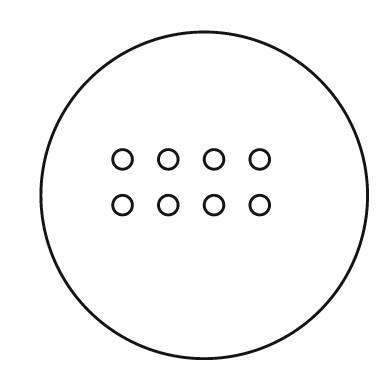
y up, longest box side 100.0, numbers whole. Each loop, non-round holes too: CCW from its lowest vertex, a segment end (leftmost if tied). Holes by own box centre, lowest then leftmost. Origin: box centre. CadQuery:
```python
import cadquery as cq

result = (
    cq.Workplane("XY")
    .moveTo(0.0, 0.0)
    .circle(50.0)
    .moveTo(-25.0, -3.0)
    .circle(3.0)
    .moveTo(-11.0, -3.0)
    .circle(3.0)
    .moveTo(3.0, -3.0)
    .circle(3.0)
    .moveTo(17.0, -3.0)
    .circle(3.0)
    .moveTo(-25.0, 11.0)
    .circle(3.0)
    .moveTo(-11.0, 11.0)
    .circle(3.0)
    .moveTo(3.0, 11.0)
    .circle(3.0)
    .moveTo(17.0, 11.0)
    .circle(3.0)
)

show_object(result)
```